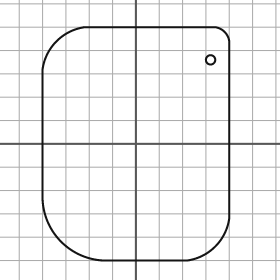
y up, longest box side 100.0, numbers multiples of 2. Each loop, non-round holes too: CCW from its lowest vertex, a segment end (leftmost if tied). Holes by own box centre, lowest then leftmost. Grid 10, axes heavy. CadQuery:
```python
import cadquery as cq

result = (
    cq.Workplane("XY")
    .moveTo(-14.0, -50.0)
    .lineTo(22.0, -50.0)
    .threePointArc((34.0, -44.0), (40.0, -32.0))
    .lineTo(40.0, 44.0)
    .threePointArc((38.0, 48.0), (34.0, 50.0))
    .lineTo(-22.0, 50.0)
    .threePointArc((-34.0, 44.0), (-40.0, 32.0))
    .lineTo(-40.0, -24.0)
    .threePointArc((-32.0, -42.0), (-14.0, -50.0))
    .close()
    .moveTo(32.0, 36.0)
    .circle(2.0)
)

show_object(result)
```